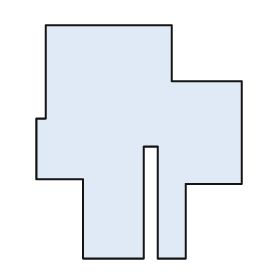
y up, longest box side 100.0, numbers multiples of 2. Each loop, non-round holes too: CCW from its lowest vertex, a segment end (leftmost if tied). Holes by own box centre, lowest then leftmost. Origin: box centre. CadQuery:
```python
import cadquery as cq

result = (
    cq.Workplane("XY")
    .moveTo(-24.0, -50.0)
    .lineTo(2.0, -50.0)
    .lineTo(2.0, -2.0)
    .lineTo(8.0, -2.0)
    .lineTo(8.0, -50.0)
    .lineTo(20.0, -50.0)
    .lineTo(20.0, -18.0)
    .lineTo(44.0, -18.0)
    .lineTo(44.0, 26.0)
    .lineTo(14.0, 26.0)
    .lineTo(14.0, 50.0)
    .lineTo(-40.0, 50.0)
    .lineTo(-40.0, 10.0)
    .lineTo(-44.0, 10.0)
    .lineTo(-44.0, -16.0)
    .lineTo(-24.0, -16.0)
    .close()
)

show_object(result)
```